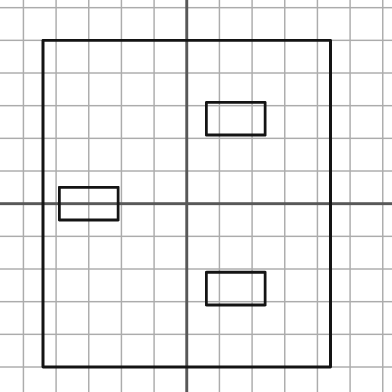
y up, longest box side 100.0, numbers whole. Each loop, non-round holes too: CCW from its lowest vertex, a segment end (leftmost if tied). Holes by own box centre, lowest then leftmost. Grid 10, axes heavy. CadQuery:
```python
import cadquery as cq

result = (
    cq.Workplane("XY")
    .moveTo(-44.0, -50.0)
    .lineTo(44.0, -50.0)
    .lineTo(44.0, 50.0)
    .lineTo(-44.0, 50.0)
    .close()
    .moveTo(6.0, -31.0)
    .lineTo(24.0, -31.0)
    .lineTo(24.0, -21.0)
    .lineTo(6.0, -21.0)
    .close()
    .moveTo(-39.0, -5.0)
    .lineTo(-21.0, -5.0)
    .lineTo(-21.0, 5.0)
    .lineTo(-39.0, 5.0)
    .close()
    .moveTo(6.0, 21.0)
    .lineTo(24.0, 21.0)
    .lineTo(24.0, 31.0)
    .lineTo(6.0, 31.0)
    .close()
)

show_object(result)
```